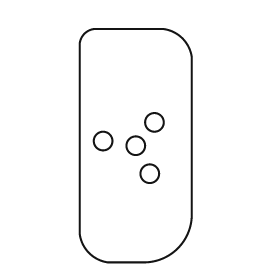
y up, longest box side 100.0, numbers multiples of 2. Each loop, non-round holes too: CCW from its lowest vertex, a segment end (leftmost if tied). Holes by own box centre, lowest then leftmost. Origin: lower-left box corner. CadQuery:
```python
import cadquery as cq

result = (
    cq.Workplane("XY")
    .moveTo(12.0, 0.0)
    .lineTo(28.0, 0.0)
    .threePointArc((42.0, 6.0), (48.0, 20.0))
    .lineTo(48.0, 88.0)
    .threePointArc((44.0, 96.0), (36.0, 100.0))
    .lineTo(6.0, 100.0)
    .threePointArc((2.0, 98.0), (0.0, 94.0))
    .lineTo(0.0, 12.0)
    .threePointArc((4.0, 4.0), (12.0, 0.0))
    .close()
    .moveTo(30.0, 38.0)
    .circle(4.0)
    .moveTo(24.0, 50.0)
    .circle(4.0)
    .moveTo(10.0, 52.0)
    .circle(4.0)
    .moveTo(32.0, 60.0)
    .circle(4.0)
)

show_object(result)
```